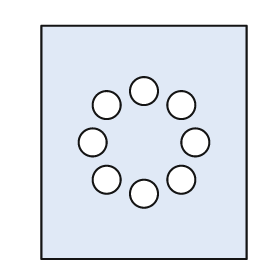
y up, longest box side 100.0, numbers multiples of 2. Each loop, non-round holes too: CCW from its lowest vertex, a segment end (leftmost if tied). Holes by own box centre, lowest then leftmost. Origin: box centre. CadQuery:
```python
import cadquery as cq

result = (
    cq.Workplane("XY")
    .moveTo(-44.0, -50.0)
    .lineTo(44.0, -50.0)
    .lineTo(44.0, 50.0)
    .lineTo(-44.0, 50.0)
    .close()
    .moveTo(0.0, -22.0)
    .circle(6.0)
    .moveTo(-16.0, -16.0)
    .circle(6.0)
    .moveTo(16.0, -16.0)
    .circle(6.0)
    .moveTo(-22.0, 0.0)
    .circle(6.0)
    .moveTo(22.0, 0.0)
    .circle(6.0)
    .moveTo(-16.0, 16.0)
    .circle(6.0)
    .moveTo(16.0, 16.0)
    .circle(6.0)
    .moveTo(0.0, 22.0)
    .circle(6.0)
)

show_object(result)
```